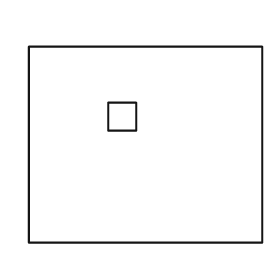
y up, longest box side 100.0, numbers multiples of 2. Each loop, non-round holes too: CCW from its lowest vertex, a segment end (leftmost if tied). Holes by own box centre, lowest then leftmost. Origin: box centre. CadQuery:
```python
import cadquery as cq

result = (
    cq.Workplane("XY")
    .moveTo(-50.0, -42.0)
    .lineTo(50.0, -42.0)
    .lineTo(50.0, 42.0)
    .lineTo(-50.0, 42.0)
    .close()
    .moveTo(-16.0, 6.0)
    .lineTo(-4.0, 6.0)
    .lineTo(-4.0, 18.0)
    .lineTo(-16.0, 18.0)
    .close()
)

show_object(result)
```